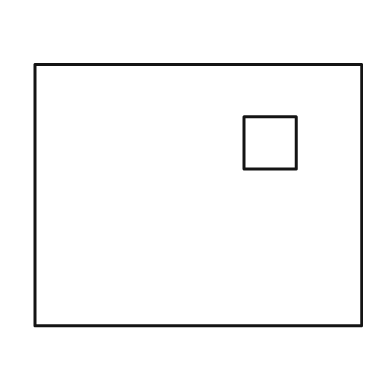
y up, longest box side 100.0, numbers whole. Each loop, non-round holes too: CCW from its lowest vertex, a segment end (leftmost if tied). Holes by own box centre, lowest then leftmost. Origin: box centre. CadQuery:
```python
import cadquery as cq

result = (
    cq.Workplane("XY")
    .moveTo(-50.0, -40.0)
    .lineTo(50.0, -40.0)
    .lineTo(50.0, 40.0)
    .lineTo(-50.0, 40.0)
    .close()
    .moveTo(14.0, 8.0)
    .lineTo(30.0, 8.0)
    .lineTo(30.0, 24.0)
    .lineTo(14.0, 24.0)
    .close()
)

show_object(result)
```